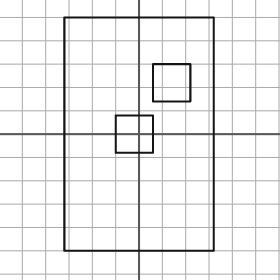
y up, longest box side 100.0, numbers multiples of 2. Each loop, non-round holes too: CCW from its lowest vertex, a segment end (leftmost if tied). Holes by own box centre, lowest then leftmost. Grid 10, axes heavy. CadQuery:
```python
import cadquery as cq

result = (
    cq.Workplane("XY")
    .moveTo(-32.0, -50.0)
    .lineTo(32.0, -50.0)
    .lineTo(32.0, 50.0)
    .lineTo(-32.0, 50.0)
    .close()
    .moveTo(-10.0, -8.0)
    .lineTo(6.0, -8.0)
    .lineTo(6.0, 8.0)
    .lineTo(-10.0, 8.0)
    .close()
    .moveTo(6.0, 14.0)
    .lineTo(22.0, 14.0)
    .lineTo(22.0, 30.0)
    .lineTo(6.0, 30.0)
    .close()
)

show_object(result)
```